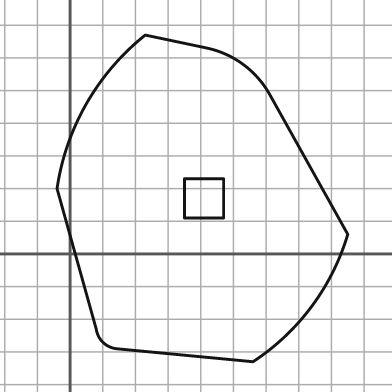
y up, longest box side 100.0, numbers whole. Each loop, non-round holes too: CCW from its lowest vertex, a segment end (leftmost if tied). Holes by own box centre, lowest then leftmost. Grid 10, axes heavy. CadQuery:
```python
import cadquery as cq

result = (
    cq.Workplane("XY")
    .moveTo(56.0, -33.0)
    .threePointArc((74.0, -16.0), (85.0, 6.0))
    .lineTo(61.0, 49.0)
    .threePointArc((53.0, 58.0), (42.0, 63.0))
    .lineTo(23.0, 67.0)
    .threePointArc((5.0, 46.0), (-4.0, 20.0))
    .lineTo(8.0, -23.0)
    .threePointArc((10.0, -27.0), (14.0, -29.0))
    .close()
    .moveTo(35.0, 11.0)
    .lineTo(47.0, 11.0)
    .lineTo(47.0, 23.0)
    .lineTo(35.0, 23.0)
    .close()
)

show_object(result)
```